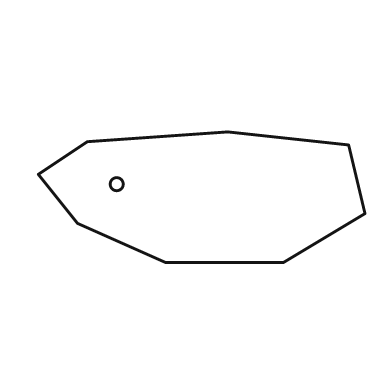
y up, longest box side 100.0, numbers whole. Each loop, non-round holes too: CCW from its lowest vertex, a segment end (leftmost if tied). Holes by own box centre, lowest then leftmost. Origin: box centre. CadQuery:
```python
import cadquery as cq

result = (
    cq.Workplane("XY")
    .moveTo(-11.0, -20.0)
    .lineTo(25.0, -20.0)
    .lineTo(50.0, -5.0)
    .lineTo(45.0, 16.0)
    .lineTo(8.0, 20.0)
    .lineTo(-35.0, 17.0)
    .lineTo(-50.0, 7.0)
    .lineTo(-38.0, -8.0)
    .close()
    .moveTo(-26.0, 4.0)
    .circle(2.0)
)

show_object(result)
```